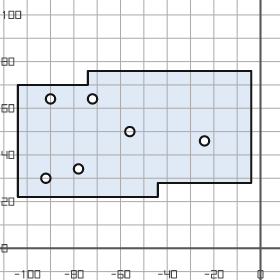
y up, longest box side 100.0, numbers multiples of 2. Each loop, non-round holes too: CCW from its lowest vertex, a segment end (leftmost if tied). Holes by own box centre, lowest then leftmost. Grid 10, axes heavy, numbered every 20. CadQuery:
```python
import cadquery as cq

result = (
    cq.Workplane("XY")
    .moveTo(-104.0, 22.0)
    .lineTo(-44.0, 22.0)
    .lineTo(-44.0, 28.0)
    .lineTo(-4.0, 28.0)
    .lineTo(-4.0, 76.0)
    .lineTo(-74.0, 76.0)
    .lineTo(-74.0, 70.0)
    .lineTo(-104.0, 70.0)
    .close()
    .moveTo(-92.0, 30.0)
    .circle(2.0)
    .moveTo(-78.0, 34.0)
    .circle(2.0)
    .moveTo(-24.0, 46.0)
    .circle(2.0)
    .moveTo(-56.0, 50.0)
    .circle(2.0)
    .moveTo(-90.0, 64.0)
    .circle(2.0)
    .moveTo(-72.0, 64.0)
    .circle(2.0)
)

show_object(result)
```